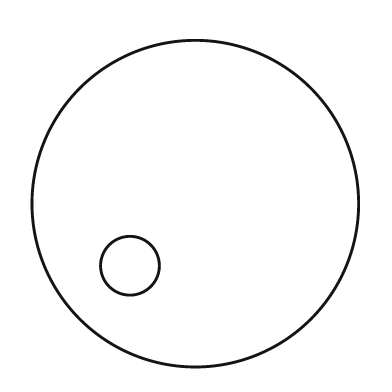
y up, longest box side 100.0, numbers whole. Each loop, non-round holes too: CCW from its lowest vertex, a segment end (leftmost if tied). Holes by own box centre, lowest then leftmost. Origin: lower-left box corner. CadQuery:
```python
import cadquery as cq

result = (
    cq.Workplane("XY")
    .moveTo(50.0, 50.0)
    .circle(50.0)
    .moveTo(30.0, 31.0)
    .circle(9.0)
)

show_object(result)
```